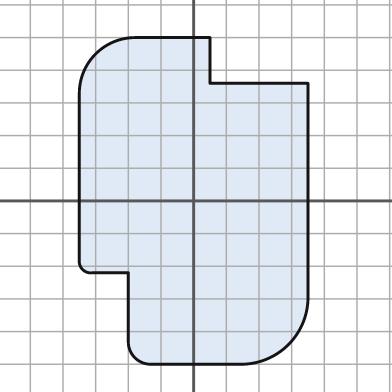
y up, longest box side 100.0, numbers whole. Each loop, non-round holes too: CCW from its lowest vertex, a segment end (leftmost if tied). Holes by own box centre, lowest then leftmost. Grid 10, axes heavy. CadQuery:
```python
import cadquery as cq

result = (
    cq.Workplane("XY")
    .moveTo(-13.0, -50.0)
    .lineTo(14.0, -50.0)
    .threePointArc((29.0, -44.0), (35.0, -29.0))
    .lineTo(35.0, 36.0)
    .lineTo(5.0, 36.0)
    .lineTo(5.0, 50.0)
    .lineTo(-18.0, 50.0)
    .threePointArc((-30.0, 45.0), (-35.0, 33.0))
    .lineTo(-35.0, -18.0)
    .threePointArc((-34.0, -21.0), (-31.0, -22.0))
    .lineTo(-20.0, -22.0)
    .lineTo(-20.0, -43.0)
    .threePointArc((-18.0, -48.0), (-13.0, -50.0))
    .close()
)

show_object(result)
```